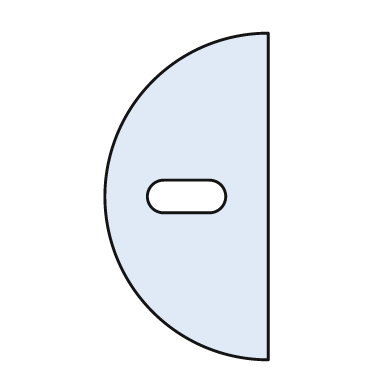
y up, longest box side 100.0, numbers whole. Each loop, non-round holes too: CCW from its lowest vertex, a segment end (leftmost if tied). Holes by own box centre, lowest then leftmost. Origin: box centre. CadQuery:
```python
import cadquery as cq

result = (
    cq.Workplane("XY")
    .moveTo(25.0, -50.0)
    .lineTo(25.0, 50.0)
    .threePointArc((-25.0, 0.0), (25.0, -50.0))
    .close()
    .moveTo(-7.0, -5.0)
    .lineTo(7.0, -5.0)
    .threePointArc((12.0, 0.0), (7.0, 5.0))
    .lineTo(-7.0, 5.0)
    .threePointArc((-12.0, 0.0), (-7.0, -5.0))
    .close()
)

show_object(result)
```